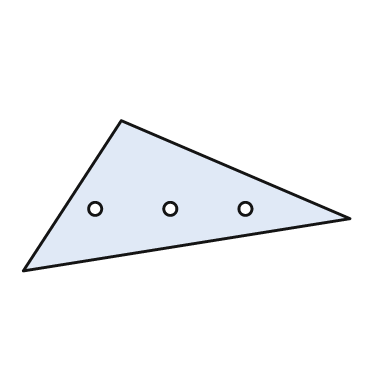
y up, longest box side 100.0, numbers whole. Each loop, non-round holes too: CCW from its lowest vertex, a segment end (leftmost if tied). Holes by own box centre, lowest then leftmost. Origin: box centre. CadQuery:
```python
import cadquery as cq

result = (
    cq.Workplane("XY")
    .moveTo(-50.0, -23.0)
    .lineTo(50.0, -7.0)
    .lineTo(-20.0, 23.0)
    .close()
    .moveTo(-28.0, -4.0)
    .circle(2.0)
    .moveTo(-5.0, -4.0)
    .circle(2.0)
    .moveTo(18.0, -4.0)
    .circle(2.0)
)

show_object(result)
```